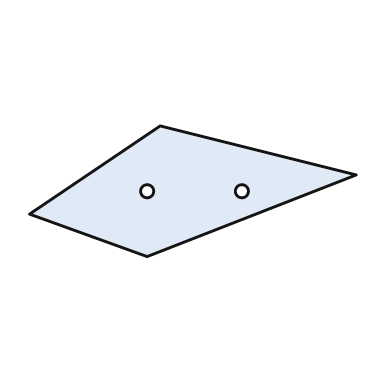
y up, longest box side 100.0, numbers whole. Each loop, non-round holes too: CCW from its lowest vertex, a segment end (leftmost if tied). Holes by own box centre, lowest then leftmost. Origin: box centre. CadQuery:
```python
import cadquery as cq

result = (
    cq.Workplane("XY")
    .moveTo(-14.0, -20.0)
    .lineTo(50.0, 5.0)
    .lineTo(-10.0, 20.0)
    .lineTo(-50.0, -7.0)
    .close()
    .moveTo(-14.0, 0.0)
    .circle(2.0)
    .moveTo(15.0, 0.0)
    .circle(2.0)
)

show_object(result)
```